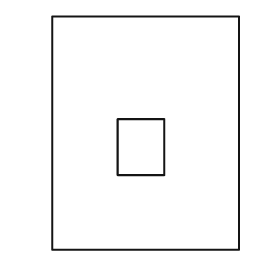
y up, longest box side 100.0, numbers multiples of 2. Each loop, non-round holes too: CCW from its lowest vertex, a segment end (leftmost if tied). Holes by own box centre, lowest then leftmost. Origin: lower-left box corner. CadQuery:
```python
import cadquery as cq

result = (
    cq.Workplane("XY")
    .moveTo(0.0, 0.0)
    .lineTo(80.0, 0.0)
    .lineTo(80.0, 100.0)
    .lineTo(0.0, 100.0)
    .close()
    .moveTo(28.0, 32.0)
    .lineTo(48.0, 32.0)
    .lineTo(48.0, 56.0)
    .lineTo(28.0, 56.0)
    .close()
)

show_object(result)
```